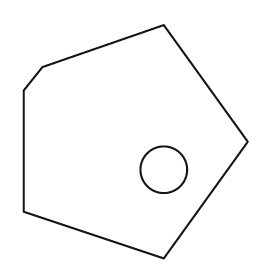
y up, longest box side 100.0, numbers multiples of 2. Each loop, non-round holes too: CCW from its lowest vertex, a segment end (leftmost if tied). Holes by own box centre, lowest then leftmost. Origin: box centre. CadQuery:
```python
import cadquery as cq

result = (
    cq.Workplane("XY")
    .moveTo(12.0, -50.0)
    .lineTo(48.0, 0.0)
    .lineTo(12.0, 50.0)
    .lineTo(-40.0, 32.0)
    .lineTo(-48.0, 22.0)
    .lineTo(-48.0, -30.0)
    .close()
    .moveTo(12.0, -12.0)
    .circle(10.0)
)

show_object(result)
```